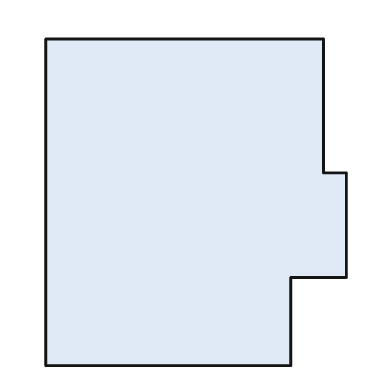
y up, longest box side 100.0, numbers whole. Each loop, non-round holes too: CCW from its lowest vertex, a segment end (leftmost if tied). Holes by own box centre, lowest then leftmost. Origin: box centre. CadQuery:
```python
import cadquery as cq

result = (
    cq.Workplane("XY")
    .moveTo(-46.0, -50.0)
    .lineTo(29.0, -50.0)
    .lineTo(29.0, -23.0)
    .lineTo(46.0, -23.0)
    .lineTo(46.0, 9.0)
    .lineTo(39.0, 9.0)
    .lineTo(39.0, 50.0)
    .lineTo(-46.0, 50.0)
    .close()
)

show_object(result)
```